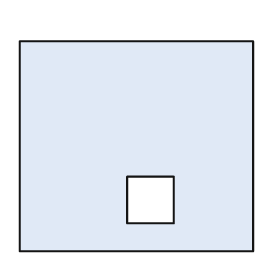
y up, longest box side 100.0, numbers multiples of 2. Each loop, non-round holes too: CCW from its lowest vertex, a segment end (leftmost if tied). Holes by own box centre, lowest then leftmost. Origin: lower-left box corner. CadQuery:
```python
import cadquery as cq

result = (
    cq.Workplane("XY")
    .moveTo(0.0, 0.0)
    .lineTo(100.0, 0.0)
    .lineTo(100.0, 90.0)
    .lineTo(0.0, 90.0)
    .close()
    .moveTo(46.0, 12.0)
    .lineTo(66.0, 12.0)
    .lineTo(66.0, 32.0)
    .lineTo(46.0, 32.0)
    .close()
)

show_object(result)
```